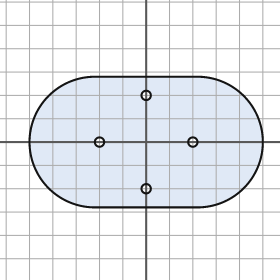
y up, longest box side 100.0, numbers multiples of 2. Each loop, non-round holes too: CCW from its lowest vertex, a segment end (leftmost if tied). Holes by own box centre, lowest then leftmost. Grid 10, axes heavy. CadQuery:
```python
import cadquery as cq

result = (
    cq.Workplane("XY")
    .moveTo(-22.0, -28.0)
    .lineTo(22.0, -28.0)
    .threePointArc((50.0, 0.0), (22.0, 28.0))
    .lineTo(-22.0, 28.0)
    .threePointArc((-50.0, 0.0), (-22.0, -28.0))
    .close()
    .moveTo(0.0, -20.0)
    .circle(2.0)
    .moveTo(-20.0, 0.0)
    .circle(2.0)
    .moveTo(20.0, 0.0)
    .circle(2.0)
    .moveTo(0.0, 20.0)
    .circle(2.0)
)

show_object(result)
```